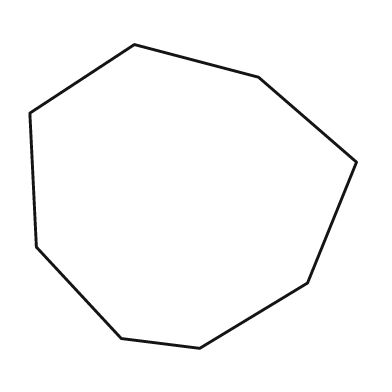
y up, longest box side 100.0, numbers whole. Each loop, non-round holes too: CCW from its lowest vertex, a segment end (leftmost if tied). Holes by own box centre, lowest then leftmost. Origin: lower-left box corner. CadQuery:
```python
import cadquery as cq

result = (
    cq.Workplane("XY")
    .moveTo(52.0, 0.0)
    .lineTo(85.0, 20.0)
    .lineTo(100.0, 57.0)
    .lineTo(70.0, 83.0)
    .lineTo(32.0, 93.0)
    .lineTo(0.0, 72.0)
    .lineTo(2.0, 31.0)
    .lineTo(28.0, 3.0)
    .close()
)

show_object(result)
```